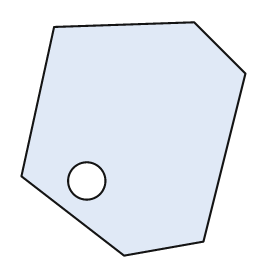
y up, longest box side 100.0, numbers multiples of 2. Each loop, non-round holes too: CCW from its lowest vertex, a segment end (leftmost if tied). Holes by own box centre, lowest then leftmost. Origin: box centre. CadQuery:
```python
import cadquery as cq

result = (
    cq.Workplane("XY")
    .moveTo(-4.0, -50.0)
    .lineTo(30.0, -44.0)
    .lineTo(48.0, 28.0)
    .lineTo(26.0, 50.0)
    .lineTo(-34.0, 48.0)
    .lineTo(-48.0, -16.0)
    .close()
    .moveTo(-20.0, -18.0)
    .circle(8.0)
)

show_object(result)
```